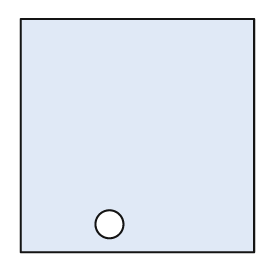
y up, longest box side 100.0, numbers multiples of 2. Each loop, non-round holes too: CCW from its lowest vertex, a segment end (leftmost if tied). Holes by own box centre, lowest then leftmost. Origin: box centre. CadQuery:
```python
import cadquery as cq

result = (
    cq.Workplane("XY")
    .moveTo(-50.0, -50.0)
    .lineTo(50.0, -50.0)
    .lineTo(50.0, 50.0)
    .lineTo(-50.0, 50.0)
    .close()
    .moveTo(-12.0, -38.0)
    .circle(6.0)
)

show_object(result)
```